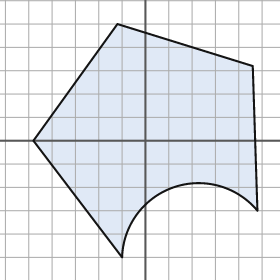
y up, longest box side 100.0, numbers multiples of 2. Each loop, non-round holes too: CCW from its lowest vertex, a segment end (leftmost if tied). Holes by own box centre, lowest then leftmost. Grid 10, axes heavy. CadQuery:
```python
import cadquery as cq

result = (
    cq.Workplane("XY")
    .moveTo(-10.0, -50.0)
    .threePointArc((12.0, -20.0), (48.0, -30.0))
    .lineTo(46.0, 32.0)
    .lineTo(-12.0, 50.0)
    .lineTo(-48.0, 0.0)
    .close()
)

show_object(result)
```